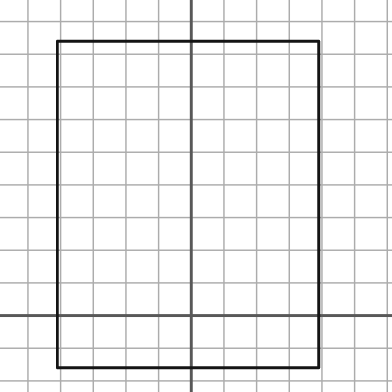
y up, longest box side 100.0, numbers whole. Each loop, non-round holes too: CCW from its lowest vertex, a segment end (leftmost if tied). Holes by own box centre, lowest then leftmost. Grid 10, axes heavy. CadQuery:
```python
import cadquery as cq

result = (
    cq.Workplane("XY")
    .moveTo(-41.0, -16.0)
    .lineTo(39.0, -16.0)
    .lineTo(39.0, 84.0)
    .lineTo(-41.0, 84.0)
    .close()
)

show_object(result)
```